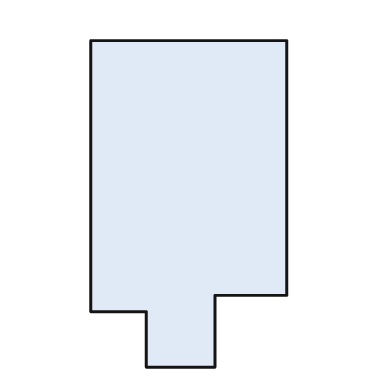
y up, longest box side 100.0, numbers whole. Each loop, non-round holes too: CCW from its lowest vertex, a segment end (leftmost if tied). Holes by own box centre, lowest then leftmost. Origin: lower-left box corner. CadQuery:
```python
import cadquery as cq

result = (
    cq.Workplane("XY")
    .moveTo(17.0, 0.0)
    .lineTo(38.0, 0.0)
    .lineTo(38.0, 22.0)
    .lineTo(60.0, 22.0)
    .lineTo(60.0, 100.0)
    .lineTo(0.0, 100.0)
    .lineTo(0.0, 17.0)
    .lineTo(17.0, 17.0)
    .close()
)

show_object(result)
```